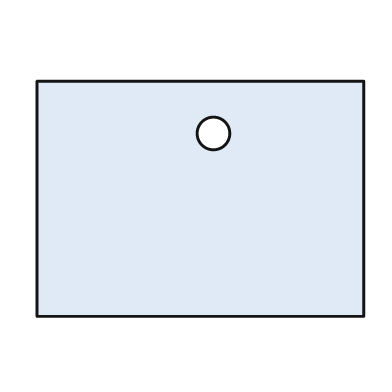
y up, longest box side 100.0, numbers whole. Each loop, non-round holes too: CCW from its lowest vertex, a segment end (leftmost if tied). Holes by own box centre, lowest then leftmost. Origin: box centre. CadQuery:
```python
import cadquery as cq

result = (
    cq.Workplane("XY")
    .moveTo(-50.0, -36.0)
    .lineTo(50.0, -36.0)
    .lineTo(50.0, 36.0)
    .lineTo(-50.0, 36.0)
    .close()
    .moveTo(4.0, 20.0)
    .circle(5.0)
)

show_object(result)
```